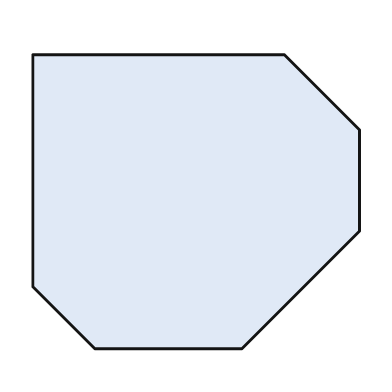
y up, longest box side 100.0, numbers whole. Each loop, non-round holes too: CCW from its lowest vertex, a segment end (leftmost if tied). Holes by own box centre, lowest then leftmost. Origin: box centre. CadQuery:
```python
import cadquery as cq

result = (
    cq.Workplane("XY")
    .moveTo(-31.0, -45.0)
    .lineTo(14.0, -45.0)
    .lineTo(50.0, -9.0)
    .lineTo(50.0, 22.0)
    .lineTo(27.0, 45.0)
    .lineTo(-50.0, 45.0)
    .lineTo(-50.0, -26.0)
    .close()
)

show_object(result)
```